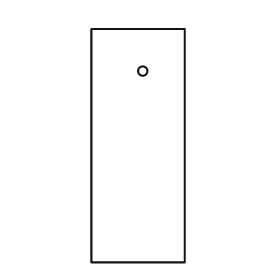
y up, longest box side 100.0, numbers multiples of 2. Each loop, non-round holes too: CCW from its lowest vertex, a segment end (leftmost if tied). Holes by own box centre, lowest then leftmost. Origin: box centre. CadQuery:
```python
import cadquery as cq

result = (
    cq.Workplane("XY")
    .moveTo(-20.0, -50.0)
    .lineTo(20.0, -50.0)
    .lineTo(20.0, 50.0)
    .lineTo(-20.0, 50.0)
    .close()
    .moveTo(2.0, 32.0)
    .circle(2.0)
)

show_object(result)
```